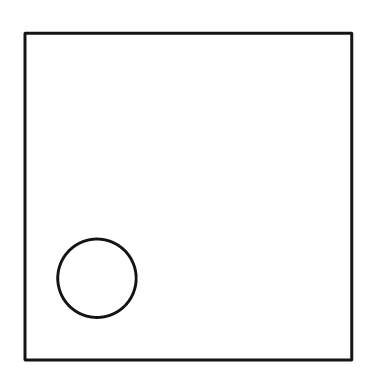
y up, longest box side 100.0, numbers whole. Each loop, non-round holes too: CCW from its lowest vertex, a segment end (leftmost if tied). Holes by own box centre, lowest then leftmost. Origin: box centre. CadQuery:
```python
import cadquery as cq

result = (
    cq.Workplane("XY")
    .moveTo(-50.0, -50.0)
    .lineTo(50.0, -50.0)
    .lineTo(50.0, 50.0)
    .lineTo(-50.0, 50.0)
    .close()
    .moveTo(-28.0, -25.0)
    .circle(12.0)
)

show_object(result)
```